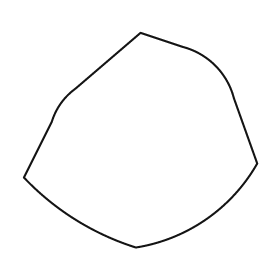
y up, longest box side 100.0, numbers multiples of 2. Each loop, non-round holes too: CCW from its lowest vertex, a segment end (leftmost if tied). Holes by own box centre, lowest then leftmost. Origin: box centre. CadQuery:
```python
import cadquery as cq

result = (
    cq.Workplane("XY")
    .moveTo(-2.0, -46.0)
    .threePointArc((28.0, -34.0), (50.0, -10.0))
    .lineTo(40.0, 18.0)
    .threePointArc((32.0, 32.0), (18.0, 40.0))
    .lineTo(0.0, 46.0)
    .lineTo(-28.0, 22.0)
    .threePointArc((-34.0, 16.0), (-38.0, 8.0))
    .lineTo(-50.0, -16.0)
    .threePointArc((-28.0, -34.0), (-2.0, -46.0))
    .close()
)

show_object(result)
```